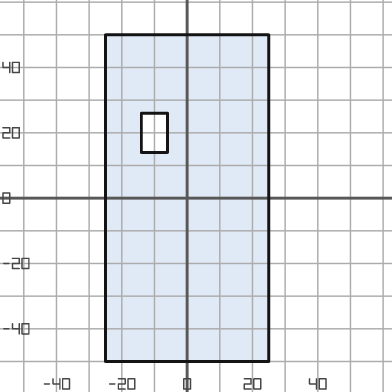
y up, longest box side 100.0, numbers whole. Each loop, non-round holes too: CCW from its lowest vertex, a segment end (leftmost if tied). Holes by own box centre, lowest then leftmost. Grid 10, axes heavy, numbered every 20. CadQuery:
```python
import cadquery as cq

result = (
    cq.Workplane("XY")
    .moveTo(-25.0, -50.0)
    .lineTo(25.0, -50.0)
    .lineTo(25.0, 50.0)
    .lineTo(-25.0, 50.0)
    .close()
    .moveTo(-14.0, 14.0)
    .lineTo(-6.0, 14.0)
    .lineTo(-6.0, 26.0)
    .lineTo(-14.0, 26.0)
    .close()
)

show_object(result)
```